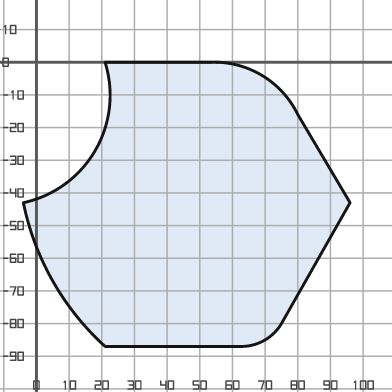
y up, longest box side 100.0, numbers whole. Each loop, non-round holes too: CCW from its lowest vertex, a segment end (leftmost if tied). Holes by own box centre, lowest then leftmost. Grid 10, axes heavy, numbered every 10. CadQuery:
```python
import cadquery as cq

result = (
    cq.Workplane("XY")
    .moveTo(21.0, -87.0)
    .lineTo(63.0, -87.0)
    .threePointArc((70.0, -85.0), (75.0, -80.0))
    .lineTo(96.0, -43.0)
    .lineTo(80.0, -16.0)
    .threePointArc((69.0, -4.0), (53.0, 0.0))
    .lineTo(21.0, 0.0)
    .threePointArc((18.0, -27.0), (-4.0, -43.0))
    .threePointArc((5.0, -67.0), (21.0, -87.0))
    .close()
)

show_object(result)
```